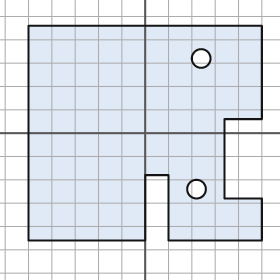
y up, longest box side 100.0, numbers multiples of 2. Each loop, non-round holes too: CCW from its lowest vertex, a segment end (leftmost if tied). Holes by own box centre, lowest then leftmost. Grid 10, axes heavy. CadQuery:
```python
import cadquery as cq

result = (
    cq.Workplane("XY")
    .moveTo(-50.0, -46.0)
    .lineTo(0.0, -46.0)
    .lineTo(0.0, -18.0)
    .lineTo(10.0, -18.0)
    .lineTo(10.0, -46.0)
    .lineTo(50.0, -46.0)
    .lineTo(50.0, -28.0)
    .lineTo(34.0, -28.0)
    .lineTo(34.0, 6.0)
    .lineTo(50.0, 6.0)
    .lineTo(50.0, 46.0)
    .lineTo(-50.0, 46.0)
    .close()
    .moveTo(22.0, -24.0)
    .circle(4.0)
    .moveTo(24.0, 32.0)
    .circle(4.0)
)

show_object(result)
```